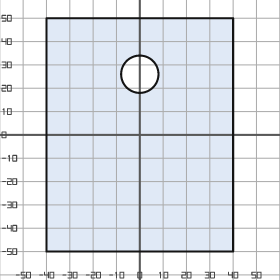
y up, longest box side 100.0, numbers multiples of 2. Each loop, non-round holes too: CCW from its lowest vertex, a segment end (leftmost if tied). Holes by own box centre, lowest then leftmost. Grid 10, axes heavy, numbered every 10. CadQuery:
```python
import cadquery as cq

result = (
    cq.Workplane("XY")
    .moveTo(-40.0, -50.0)
    .lineTo(40.0, -50.0)
    .lineTo(40.0, 50.0)
    .lineTo(-40.0, 50.0)
    .close()
    .moveTo(0.0, 26.0)
    .circle(8.0)
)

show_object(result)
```